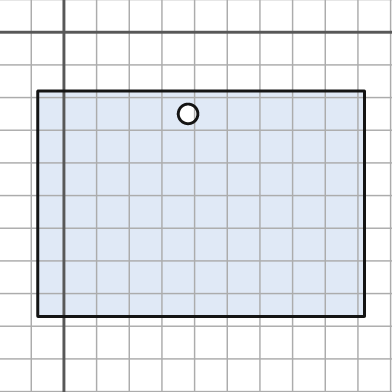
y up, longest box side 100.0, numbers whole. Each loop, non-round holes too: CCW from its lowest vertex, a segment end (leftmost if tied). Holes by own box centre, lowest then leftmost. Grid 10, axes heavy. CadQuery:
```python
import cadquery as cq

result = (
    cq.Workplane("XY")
    .moveTo(-8.0, -87.0)
    .lineTo(92.0, -87.0)
    .lineTo(92.0, -18.0)
    .lineTo(-8.0, -18.0)
    .close()
    .moveTo(38.0, -25.0)
    .circle(3.0)
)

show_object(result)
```